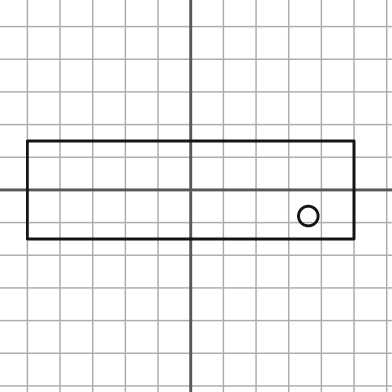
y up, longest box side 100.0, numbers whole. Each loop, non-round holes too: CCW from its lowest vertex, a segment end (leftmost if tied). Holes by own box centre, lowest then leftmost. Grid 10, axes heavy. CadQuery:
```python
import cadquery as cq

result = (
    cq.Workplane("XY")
    .moveTo(-50.0, -15.0)
    .lineTo(50.0, -15.0)
    .lineTo(50.0, 15.0)
    .lineTo(-50.0, 15.0)
    .close()
    .moveTo(36.0, -8.0)
    .circle(3.0)
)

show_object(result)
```